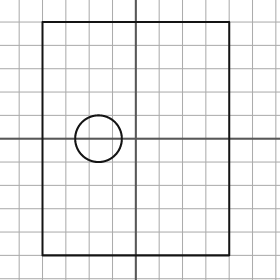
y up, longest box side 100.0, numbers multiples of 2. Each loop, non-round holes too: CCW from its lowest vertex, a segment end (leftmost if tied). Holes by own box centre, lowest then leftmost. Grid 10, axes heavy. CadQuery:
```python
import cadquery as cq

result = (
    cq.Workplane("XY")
    .moveTo(-40.0, -50.0)
    .lineTo(40.0, -50.0)
    .lineTo(40.0, 50.0)
    .lineTo(-40.0, 50.0)
    .close()
    .moveTo(-16.0, 0.0)
    .circle(10.0)
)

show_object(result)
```